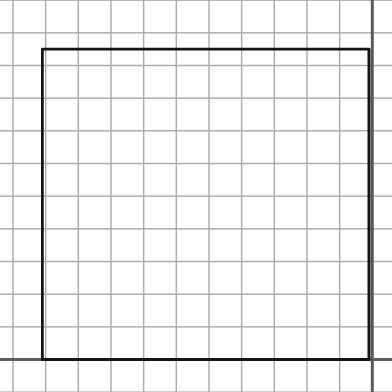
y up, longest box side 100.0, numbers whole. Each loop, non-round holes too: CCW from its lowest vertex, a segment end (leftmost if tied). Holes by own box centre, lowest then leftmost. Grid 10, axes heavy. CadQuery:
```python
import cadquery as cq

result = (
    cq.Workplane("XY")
    .moveTo(-101.0, 0.0)
    .lineTo(-1.0, 0.0)
    .lineTo(-1.0, 95.0)
    .lineTo(-101.0, 95.0)
    .close()
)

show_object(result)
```